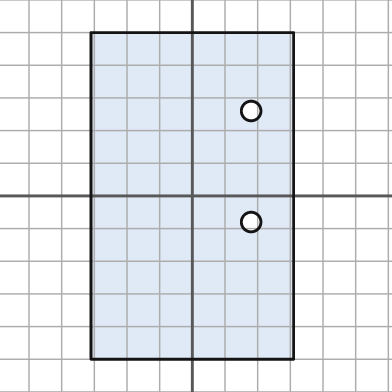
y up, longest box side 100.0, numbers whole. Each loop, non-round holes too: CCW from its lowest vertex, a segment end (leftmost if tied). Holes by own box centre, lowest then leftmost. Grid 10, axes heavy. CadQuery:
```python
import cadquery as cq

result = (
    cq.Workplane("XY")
    .moveTo(-31.0, -50.0)
    .lineTo(31.0, -50.0)
    .lineTo(31.0, 50.0)
    .lineTo(-31.0, 50.0)
    .close()
    .moveTo(18.0, -8.0)
    .circle(3.0)
    .moveTo(18.0, 26.0)
    .circle(3.0)
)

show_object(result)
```